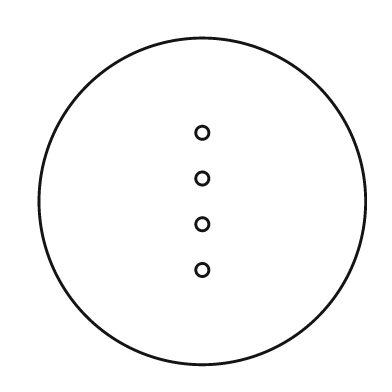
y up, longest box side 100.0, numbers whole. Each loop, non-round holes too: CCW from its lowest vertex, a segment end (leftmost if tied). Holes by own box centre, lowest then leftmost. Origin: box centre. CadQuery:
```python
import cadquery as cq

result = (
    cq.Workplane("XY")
    .moveTo(0.0, 0.0)
    .circle(50.0)
    .moveTo(0.0, -21.0)
    .circle(2.0)
    .moveTo(0.0, -7.0)
    .circle(2.0)
    .moveTo(0.0, 7.0)
    .circle(2.0)
    .moveTo(0.0, 21.0)
    .circle(2.0)
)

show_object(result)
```